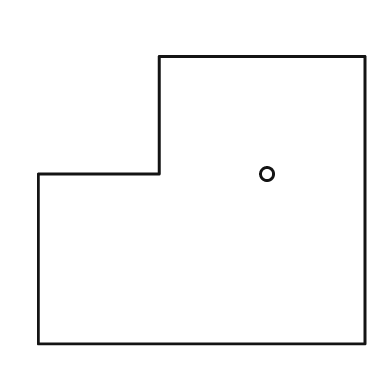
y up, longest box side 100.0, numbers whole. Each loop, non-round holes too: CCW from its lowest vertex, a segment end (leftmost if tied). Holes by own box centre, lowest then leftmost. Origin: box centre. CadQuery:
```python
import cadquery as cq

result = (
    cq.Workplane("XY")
    .moveTo(-50.0, -44.0)
    .lineTo(50.0, -44.0)
    .lineTo(50.0, 44.0)
    .lineTo(-13.0, 44.0)
    .lineTo(-13.0, 8.0)
    .lineTo(-50.0, 8.0)
    .close()
    .moveTo(20.0, 8.0)
    .circle(2.0)
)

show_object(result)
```